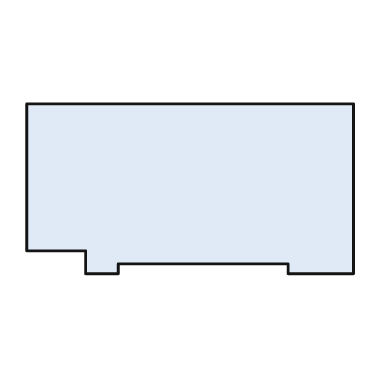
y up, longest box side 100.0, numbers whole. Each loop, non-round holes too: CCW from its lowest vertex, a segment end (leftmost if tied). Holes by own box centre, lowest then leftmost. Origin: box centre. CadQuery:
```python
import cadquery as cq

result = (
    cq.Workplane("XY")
    .moveTo(-32.0, -26.0)
    .lineTo(-22.0, -26.0)
    .lineTo(-22.0, -23.0)
    .lineTo(30.0, -23.0)
    .lineTo(30.0, -26.0)
    .lineTo(50.0, -26.0)
    .lineTo(50.0, 26.0)
    .lineTo(-50.0, 26.0)
    .lineTo(-50.0, -19.0)
    .lineTo(-32.0, -19.0)
    .close()
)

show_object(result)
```